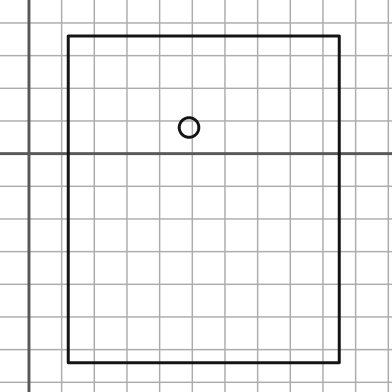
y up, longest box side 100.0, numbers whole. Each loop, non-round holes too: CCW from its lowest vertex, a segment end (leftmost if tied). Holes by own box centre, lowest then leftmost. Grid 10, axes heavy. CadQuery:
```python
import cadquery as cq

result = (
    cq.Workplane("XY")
    .moveTo(12.0, -64.0)
    .lineTo(95.0, -64.0)
    .lineTo(95.0, 36.0)
    .lineTo(12.0, 36.0)
    .close()
    .moveTo(49.0, 8.0)
    .circle(3.0)
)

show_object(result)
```